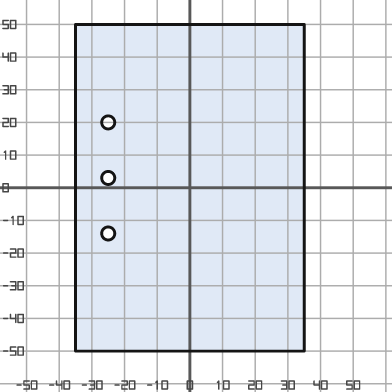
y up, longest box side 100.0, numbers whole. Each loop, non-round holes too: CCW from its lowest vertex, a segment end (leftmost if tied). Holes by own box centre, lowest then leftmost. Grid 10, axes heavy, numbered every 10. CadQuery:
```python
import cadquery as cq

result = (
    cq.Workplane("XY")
    .moveTo(-35.0, -50.0)
    .lineTo(35.0, -50.0)
    .lineTo(35.0, 50.0)
    .lineTo(-35.0, 50.0)
    .close()
    .moveTo(-25.0, -14.0)
    .circle(2.0)
    .moveTo(-25.0, 3.0)
    .circle(2.0)
    .moveTo(-25.0, 20.0)
    .circle(2.0)
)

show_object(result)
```